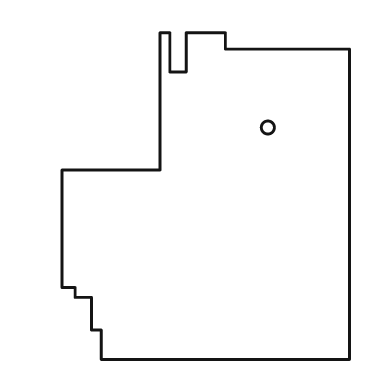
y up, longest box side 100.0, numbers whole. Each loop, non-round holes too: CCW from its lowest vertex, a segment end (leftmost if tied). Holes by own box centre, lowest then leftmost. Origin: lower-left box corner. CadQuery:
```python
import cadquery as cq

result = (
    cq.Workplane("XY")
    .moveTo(12.0, 0.0)
    .lineTo(88.0, 0.0)
    .lineTo(88.0, 95.0)
    .lineTo(50.0, 95.0)
    .lineTo(50.0, 100.0)
    .lineTo(38.0, 100.0)
    .lineTo(38.0, 88.0)
    .lineTo(33.0, 88.0)
    .lineTo(33.0, 100.0)
    .lineTo(30.0, 100.0)
    .lineTo(30.0, 58.0)
    .lineTo(0.0, 58.0)
    .lineTo(0.0, 22.0)
    .lineTo(4.0, 22.0)
    .lineTo(4.0, 19.0)
    .lineTo(9.0, 19.0)
    .lineTo(9.0, 9.0)
    .lineTo(12.0, 9.0)
    .close()
    .moveTo(63.0, 71.0)
    .circle(2.0)
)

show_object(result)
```